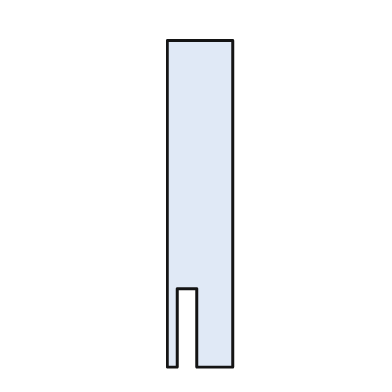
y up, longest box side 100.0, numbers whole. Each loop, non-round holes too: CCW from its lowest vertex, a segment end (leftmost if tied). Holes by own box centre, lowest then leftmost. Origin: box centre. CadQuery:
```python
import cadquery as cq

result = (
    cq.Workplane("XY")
    .moveTo(-10.0, -50.0)
    .lineTo(-7.0, -50.0)
    .lineTo(-7.0, -26.0)
    .lineTo(-1.0, -26.0)
    .lineTo(-1.0, -50.0)
    .lineTo(10.0, -50.0)
    .lineTo(10.0, 50.0)
    .lineTo(-10.0, 50.0)
    .close()
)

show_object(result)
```